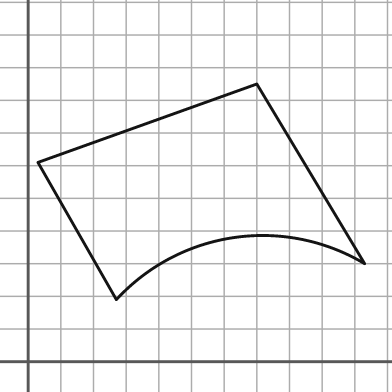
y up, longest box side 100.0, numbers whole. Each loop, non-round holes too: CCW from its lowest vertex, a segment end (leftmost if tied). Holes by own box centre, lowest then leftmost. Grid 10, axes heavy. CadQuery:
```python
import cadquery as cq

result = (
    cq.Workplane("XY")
    .moveTo(27.0, 19.0)
    .threePointArc((63.0, 38.0), (103.0, 30.0))
    .lineTo(70.0, 85.0)
    .lineTo(3.0, 61.0)
    .close()
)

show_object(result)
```